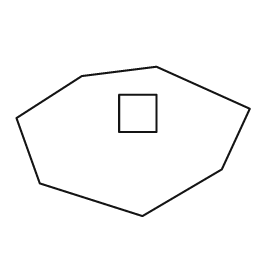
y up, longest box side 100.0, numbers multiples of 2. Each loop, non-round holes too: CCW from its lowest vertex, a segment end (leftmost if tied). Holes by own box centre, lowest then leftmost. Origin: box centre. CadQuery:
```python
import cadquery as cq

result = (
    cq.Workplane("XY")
    .moveTo(4.0, -32.0)
    .lineTo(38.0, -12.0)
    .lineTo(50.0, 14.0)
    .lineTo(10.0, 32.0)
    .lineTo(-22.0, 28.0)
    .lineTo(-50.0, 10.0)
    .lineTo(-40.0, -18.0)
    .close()
    .moveTo(-6.0, 4.0)
    .lineTo(10.0, 4.0)
    .lineTo(10.0, 20.0)
    .lineTo(-6.0, 20.0)
    .close()
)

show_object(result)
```